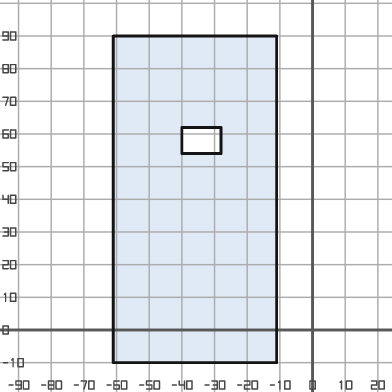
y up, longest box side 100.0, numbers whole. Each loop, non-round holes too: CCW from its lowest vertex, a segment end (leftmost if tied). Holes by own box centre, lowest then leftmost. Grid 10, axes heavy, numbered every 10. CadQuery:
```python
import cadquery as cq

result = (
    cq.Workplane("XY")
    .moveTo(-61.0, -10.0)
    .lineTo(-11.0, -10.0)
    .lineTo(-11.0, 90.0)
    .lineTo(-61.0, 90.0)
    .close()
    .moveTo(-40.0, 54.0)
    .lineTo(-28.0, 54.0)
    .lineTo(-28.0, 62.0)
    .lineTo(-40.0, 62.0)
    .close()
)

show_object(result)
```